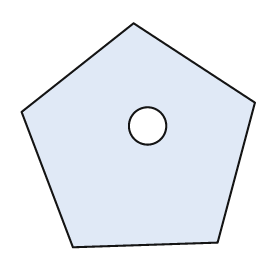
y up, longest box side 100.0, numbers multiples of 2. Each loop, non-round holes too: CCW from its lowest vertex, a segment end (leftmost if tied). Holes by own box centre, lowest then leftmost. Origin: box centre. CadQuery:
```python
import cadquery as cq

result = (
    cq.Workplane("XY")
    .moveTo(-28.0, -48.0)
    .lineTo(34.0, -46.0)
    .lineTo(50.0, 14.0)
    .lineTo(-2.0, 48.0)
    .lineTo(-50.0, 10.0)
    .close()
    .moveTo(4.0, 4.0)
    .circle(8.0)
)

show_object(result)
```